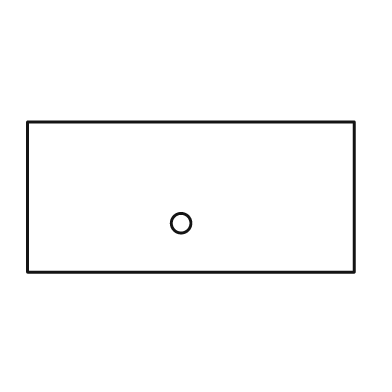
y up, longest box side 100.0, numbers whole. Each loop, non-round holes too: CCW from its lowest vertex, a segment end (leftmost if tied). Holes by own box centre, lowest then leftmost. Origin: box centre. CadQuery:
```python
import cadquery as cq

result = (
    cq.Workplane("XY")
    .moveTo(-50.0, -23.0)
    .lineTo(50.0, -23.0)
    .lineTo(50.0, 23.0)
    .lineTo(-50.0, 23.0)
    .close()
    .moveTo(-3.0, -8.0)
    .circle(3.0)
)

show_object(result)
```